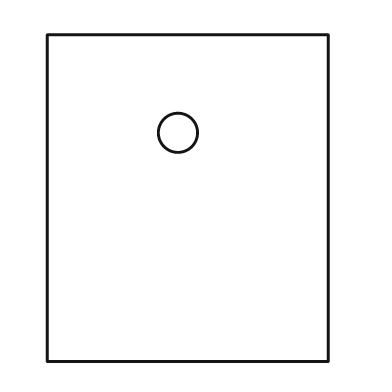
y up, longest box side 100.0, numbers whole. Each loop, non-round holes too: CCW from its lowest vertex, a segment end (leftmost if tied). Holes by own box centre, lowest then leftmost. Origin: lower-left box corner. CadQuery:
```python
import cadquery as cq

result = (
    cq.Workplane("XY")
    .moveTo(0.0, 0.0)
    .lineTo(86.0, 0.0)
    .lineTo(86.0, 100.0)
    .lineTo(0.0, 100.0)
    .close()
    .moveTo(40.0, 70.0)
    .circle(6.0)
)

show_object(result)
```